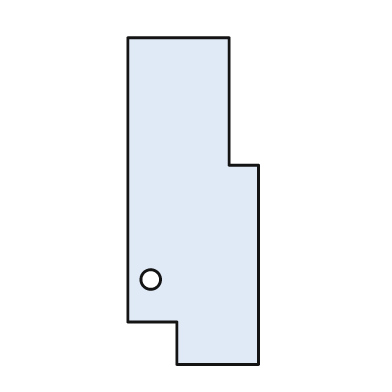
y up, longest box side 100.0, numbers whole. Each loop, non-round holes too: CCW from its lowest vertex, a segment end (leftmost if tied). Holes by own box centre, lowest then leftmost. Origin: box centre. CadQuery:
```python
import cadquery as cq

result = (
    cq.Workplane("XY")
    .moveTo(-5.0, -50.0)
    .lineTo(20.0, -50.0)
    .lineTo(20.0, 11.0)
    .lineTo(11.0, 11.0)
    .lineTo(11.0, 50.0)
    .lineTo(-20.0, 50.0)
    .lineTo(-20.0, -37.0)
    .lineTo(-5.0, -37.0)
    .close()
    .moveTo(-13.0, -24.0)
    .circle(3.0)
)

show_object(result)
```